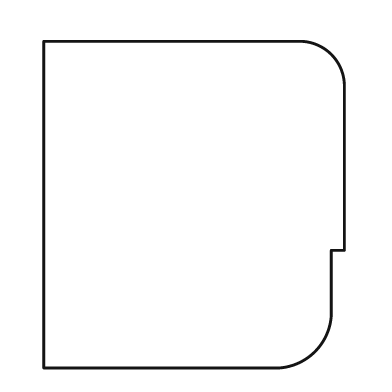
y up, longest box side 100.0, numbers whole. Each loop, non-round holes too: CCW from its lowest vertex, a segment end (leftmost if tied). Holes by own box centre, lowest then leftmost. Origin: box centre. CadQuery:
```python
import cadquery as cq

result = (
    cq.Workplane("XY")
    .moveTo(-46.0, -50.0)
    .lineTo(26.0, -50.0)
    .threePointArc((37.0, -45.0), (42.0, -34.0))
    .lineTo(42.0, -14.0)
    .lineTo(46.0, -14.0)
    .lineTo(46.0, 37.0)
    .threePointArc((42.0, 46.0), (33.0, 50.0))
    .lineTo(-46.0, 50.0)
    .close()
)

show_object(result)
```